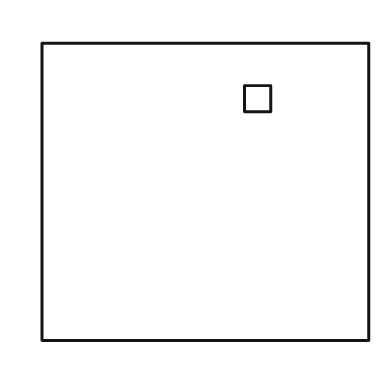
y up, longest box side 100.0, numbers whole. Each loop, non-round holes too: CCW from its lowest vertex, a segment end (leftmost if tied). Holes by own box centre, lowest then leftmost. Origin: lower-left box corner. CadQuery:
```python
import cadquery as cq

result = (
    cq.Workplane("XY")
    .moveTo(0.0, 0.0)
    .lineTo(100.0, 0.0)
    .lineTo(100.0, 91.0)
    .lineTo(0.0, 91.0)
    .close()
    .moveTo(62.0, 70.0)
    .lineTo(70.0, 70.0)
    .lineTo(70.0, 78.0)
    .lineTo(62.0, 78.0)
    .close()
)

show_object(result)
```